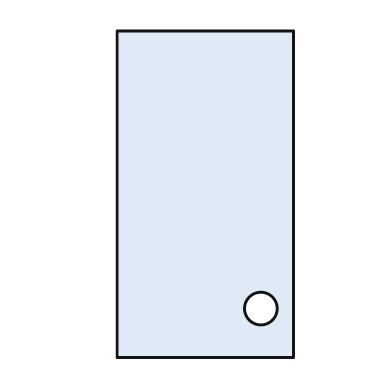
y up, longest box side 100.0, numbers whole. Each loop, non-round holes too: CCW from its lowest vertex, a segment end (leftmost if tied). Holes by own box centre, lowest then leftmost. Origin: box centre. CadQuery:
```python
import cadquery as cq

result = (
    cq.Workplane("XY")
    .moveTo(-27.0, -50.0)
    .lineTo(27.0, -50.0)
    .lineTo(27.0, 50.0)
    .lineTo(-27.0, 50.0)
    .close()
    .moveTo(17.0, -35.0)
    .circle(5.0)
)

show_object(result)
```